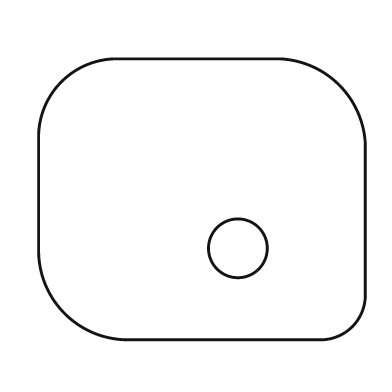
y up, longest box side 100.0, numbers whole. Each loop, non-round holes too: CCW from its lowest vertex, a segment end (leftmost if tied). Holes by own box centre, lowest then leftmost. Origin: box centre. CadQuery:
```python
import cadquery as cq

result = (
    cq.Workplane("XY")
    .moveTo(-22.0, -43.0)
    .lineTo(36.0, -43.0)
    .threePointArc((46.0, -39.0), (50.0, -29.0))
    .lineTo(50.0, 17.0)
    .threePointArc((42.0, 35.0), (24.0, 43.0))
    .lineTo(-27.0, 43.0)
    .threePointArc((-43.0, 36.0), (-50.0, 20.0))
    .lineTo(-50.0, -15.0)
    .threePointArc((-42.0, -35.0), (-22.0, -43.0))
    .close()
    .moveTo(11.0, -15.0)
    .circle(9.0)
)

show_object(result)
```